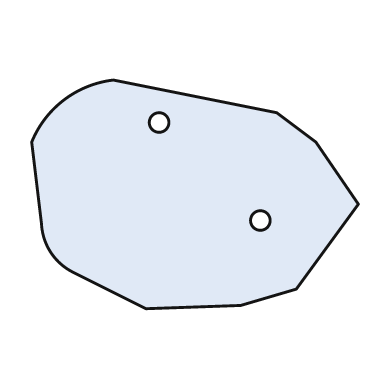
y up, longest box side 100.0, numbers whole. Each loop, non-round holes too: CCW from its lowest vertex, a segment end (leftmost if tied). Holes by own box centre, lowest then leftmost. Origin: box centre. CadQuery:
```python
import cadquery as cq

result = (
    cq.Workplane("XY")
    .moveTo(-15.0, -35.0)
    .lineTo(14.0, -34.0)
    .lineTo(31.0, -29.0)
    .lineTo(50.0, -3.0)
    .lineTo(37.0, 16.0)
    .lineTo(25.0, 25.0)
    .lineTo(-25.0, 35.0)
    .threePointArc((-40.0, 29.0), (-50.0, 16.0))
    .lineTo(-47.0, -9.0)
    .threePointArc((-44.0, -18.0), (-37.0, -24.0))
    .close()
    .moveTo(20.0, -8.0)
    .circle(3.0)
    .moveTo(-11.0, 22.0)
    .circle(3.0)
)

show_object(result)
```